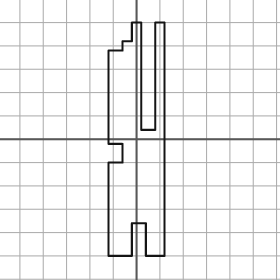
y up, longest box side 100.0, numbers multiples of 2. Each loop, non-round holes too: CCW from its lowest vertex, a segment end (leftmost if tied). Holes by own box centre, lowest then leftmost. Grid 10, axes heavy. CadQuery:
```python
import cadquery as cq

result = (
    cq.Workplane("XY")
    .moveTo(-12.0, -50.0)
    .lineTo(-2.0, -50.0)
    .lineTo(-2.0, -36.0)
    .lineTo(4.0, -36.0)
    .lineTo(4.0, -50.0)
    .lineTo(12.0, -50.0)
    .lineTo(12.0, 50.0)
    .lineTo(8.0, 50.0)
    .lineTo(8.0, 4.0)
    .lineTo(2.0, 4.0)
    .lineTo(2.0, 50.0)
    .lineTo(-2.0, 50.0)
    .lineTo(-2.0, 42.0)
    .lineTo(-6.0, 42.0)
    .lineTo(-6.0, 38.0)
    .lineTo(-12.0, 38.0)
    .lineTo(-12.0, -2.0)
    .lineTo(-6.0, -2.0)
    .lineTo(-6.0, -10.0)
    .lineTo(-12.0, -10.0)
    .close()
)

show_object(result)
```